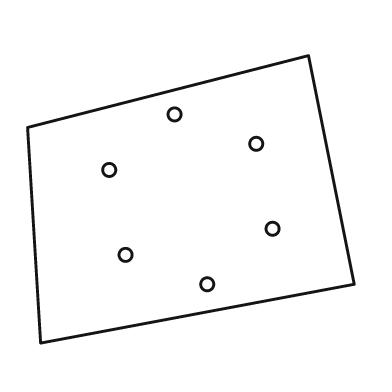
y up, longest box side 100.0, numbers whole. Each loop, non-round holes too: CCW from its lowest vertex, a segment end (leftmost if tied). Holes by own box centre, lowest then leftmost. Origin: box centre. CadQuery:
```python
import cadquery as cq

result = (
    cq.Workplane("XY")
    .moveTo(-46.0, -44.0)
    .lineTo(50.0, -26.0)
    .lineTo(36.0, 44.0)
    .lineTo(-50.0, 22.0)
    .close()
    .moveTo(5.0, -26.0)
    .circle(2.0)
    .moveTo(-20.0, -17.0)
    .circle(2.0)
    .moveTo(25.0, -9.0)
    .circle(2.0)
    .moveTo(-25.0, 9.0)
    .circle(2.0)
    .moveTo(20.0, 17.0)
    .circle(2.0)
    .moveTo(-5.0, 26.0)
    .circle(2.0)
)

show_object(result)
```